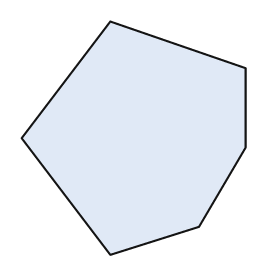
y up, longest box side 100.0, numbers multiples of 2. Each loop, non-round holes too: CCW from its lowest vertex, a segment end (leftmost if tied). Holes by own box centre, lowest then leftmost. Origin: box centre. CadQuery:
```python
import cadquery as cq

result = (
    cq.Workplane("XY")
    .moveTo(-10.0, -50.0)
    .lineTo(28.0, -38.0)
    .lineTo(48.0, -4.0)
    .lineTo(48.0, 30.0)
    .lineTo(-10.0, 50.0)
    .lineTo(-48.0, 0.0)
    .close()
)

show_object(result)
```